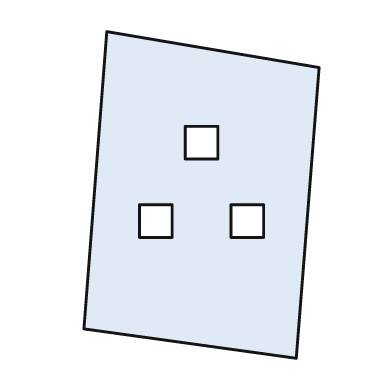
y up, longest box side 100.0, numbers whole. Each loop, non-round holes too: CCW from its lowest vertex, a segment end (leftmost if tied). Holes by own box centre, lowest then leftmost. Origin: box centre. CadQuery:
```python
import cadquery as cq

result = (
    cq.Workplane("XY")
    .moveTo(29.0, -50.0)
    .lineTo(36.0, 39.0)
    .lineTo(-29.0, 50.0)
    .lineTo(-36.0, -41.0)
    .close()
    .moveTo(-19.0, -13.0)
    .lineTo(-9.0, -13.0)
    .lineTo(-9.0, -3.0)
    .lineTo(-19.0, -3.0)
    .close()
    .moveTo(9.0, -13.0)
    .lineTo(19.0, -13.0)
    .lineTo(19.0, -3.0)
    .lineTo(9.0, -3.0)
    .close()
    .moveTo(-5.0, 11.0)
    .lineTo(5.0, 11.0)
    .lineTo(5.0, 21.0)
    .lineTo(-5.0, 21.0)
    .close()
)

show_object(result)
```